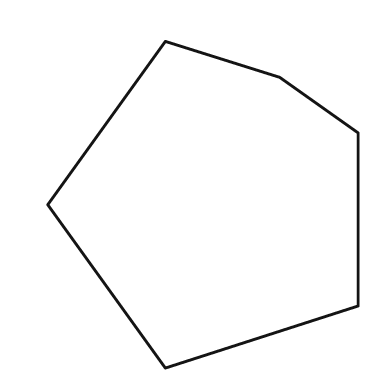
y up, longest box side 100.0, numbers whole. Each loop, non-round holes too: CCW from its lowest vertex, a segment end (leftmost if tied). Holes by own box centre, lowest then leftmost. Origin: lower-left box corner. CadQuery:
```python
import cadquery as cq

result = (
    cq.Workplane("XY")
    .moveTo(36.0, 0.0)
    .lineTo(95.0, 19.0)
    .lineTo(95.0, 72.0)
    .lineTo(71.0, 89.0)
    .lineTo(36.0, 100.0)
    .lineTo(0.0, 50.0)
    .close()
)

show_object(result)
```